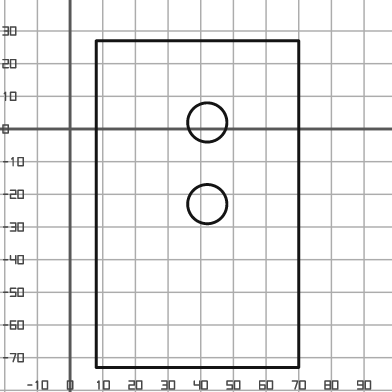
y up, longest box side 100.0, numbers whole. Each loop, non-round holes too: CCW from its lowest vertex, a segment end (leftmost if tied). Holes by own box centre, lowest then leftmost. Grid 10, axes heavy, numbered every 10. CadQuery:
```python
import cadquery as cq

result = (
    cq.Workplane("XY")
    .moveTo(8.0, -73.0)
    .lineTo(70.0, -73.0)
    .lineTo(70.0, 27.0)
    .lineTo(8.0, 27.0)
    .close()
    .moveTo(42.0, -23.0)
    .circle(6.0)
    .moveTo(42.0, 2.0)
    .circle(6.0)
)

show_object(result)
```